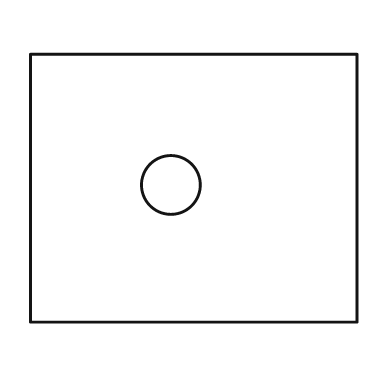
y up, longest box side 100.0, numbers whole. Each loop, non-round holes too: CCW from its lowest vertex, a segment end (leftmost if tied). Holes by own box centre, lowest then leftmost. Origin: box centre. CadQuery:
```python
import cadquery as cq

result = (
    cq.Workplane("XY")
    .moveTo(-50.0, -41.0)
    .lineTo(50.0, -41.0)
    .lineTo(50.0, 41.0)
    .lineTo(-50.0, 41.0)
    .close()
    .moveTo(-7.0, 1.0)
    .circle(9.0)
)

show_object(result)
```